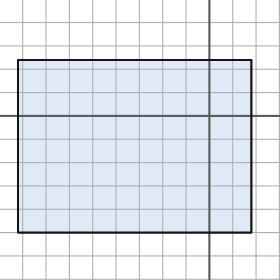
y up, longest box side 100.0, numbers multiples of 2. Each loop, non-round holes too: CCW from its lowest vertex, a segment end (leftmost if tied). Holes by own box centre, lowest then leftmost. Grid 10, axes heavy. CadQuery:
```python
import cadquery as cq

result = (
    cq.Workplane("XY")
    .moveTo(-82.0, -50.0)
    .lineTo(18.0, -50.0)
    .lineTo(18.0, 24.0)
    .lineTo(-82.0, 24.0)
    .close()
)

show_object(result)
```